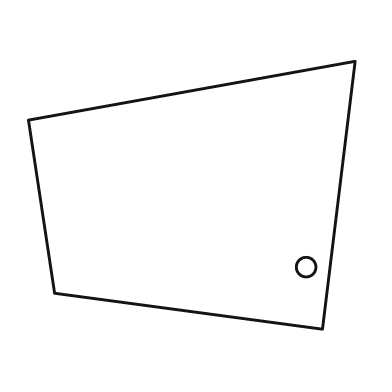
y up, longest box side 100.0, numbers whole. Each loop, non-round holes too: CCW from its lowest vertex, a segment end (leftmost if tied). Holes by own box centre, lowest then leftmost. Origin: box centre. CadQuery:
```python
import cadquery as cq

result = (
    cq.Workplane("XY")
    .moveTo(40.0, -41.0)
    .lineTo(50.0, 41.0)
    .lineTo(-50.0, 23.0)
    .lineTo(-42.0, -30.0)
    .close()
    .moveTo(35.0, -22.0)
    .circle(3.0)
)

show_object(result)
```